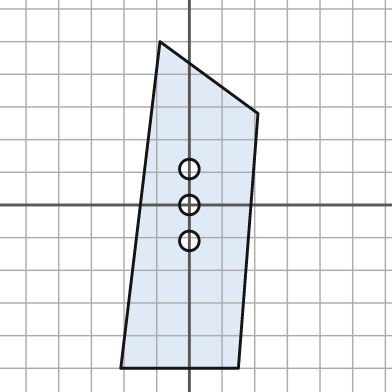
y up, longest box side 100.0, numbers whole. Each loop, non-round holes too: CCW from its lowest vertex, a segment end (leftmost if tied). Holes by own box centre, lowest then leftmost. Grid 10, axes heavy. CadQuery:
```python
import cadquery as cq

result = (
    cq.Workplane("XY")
    .moveTo(-21.0, -50.0)
    .lineTo(15.0, -50.0)
    .lineTo(21.0, 28.0)
    .lineTo(-9.0, 50.0)
    .close()
    .moveTo(0.0, -11.0)
    .circle(3.0)
    .moveTo(0.0, 0.0)
    .circle(3.0)
    .moveTo(0.0, 11.0)
    .circle(3.0)
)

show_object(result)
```